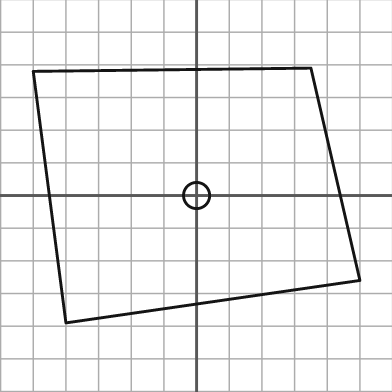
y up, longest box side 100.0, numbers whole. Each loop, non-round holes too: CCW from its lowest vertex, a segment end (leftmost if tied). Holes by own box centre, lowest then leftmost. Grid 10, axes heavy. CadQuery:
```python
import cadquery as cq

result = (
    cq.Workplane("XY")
    .moveTo(-40.0, -39.0)
    .lineTo(50.0, -26.0)
    .lineTo(35.0, 39.0)
    .lineTo(-50.0, 38.0)
    .close()
    .moveTo(0.0, 0.0)
    .circle(4.0)
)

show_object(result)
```